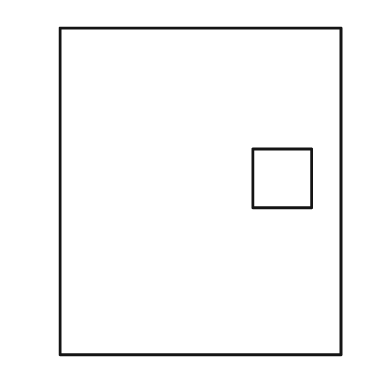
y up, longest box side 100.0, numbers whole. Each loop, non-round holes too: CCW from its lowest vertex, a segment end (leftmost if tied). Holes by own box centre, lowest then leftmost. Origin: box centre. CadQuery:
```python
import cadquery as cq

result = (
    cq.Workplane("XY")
    .moveTo(-43.0, -50.0)
    .lineTo(43.0, -50.0)
    .lineTo(43.0, 50.0)
    .lineTo(-43.0, 50.0)
    .close()
    .moveTo(16.0, -5.0)
    .lineTo(34.0, -5.0)
    .lineTo(34.0, 13.0)
    .lineTo(16.0, 13.0)
    .close()
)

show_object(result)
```